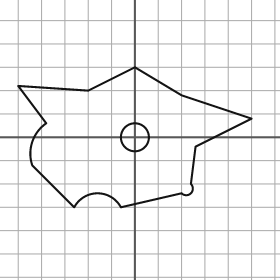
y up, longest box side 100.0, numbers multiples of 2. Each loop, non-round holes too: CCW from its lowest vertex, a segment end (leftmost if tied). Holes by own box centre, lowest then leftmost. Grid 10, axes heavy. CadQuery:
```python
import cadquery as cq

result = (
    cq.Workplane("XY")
    .moveTo(-26.0, -30.0)
    .threePointArc((-16.0, -24.0), (-6.0, -30.0))
    .lineTo(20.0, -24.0)
    .threePointArc((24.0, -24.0), (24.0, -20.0))
    .lineTo(26.0, -4.0)
    .lineTo(50.0, 8.0)
    .lineTo(20.0, 18.0)
    .lineTo(0.0, 30.0)
    .lineTo(-20.0, 20.0)
    .lineTo(-50.0, 22.0)
    .lineTo(-38.0, 6.0)
    .threePointArc((-44.0, -2.0), (-44.0, -12.0))
    .close()
    .moveTo(0.0, 0.0)
    .circle(6.0)
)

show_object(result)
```